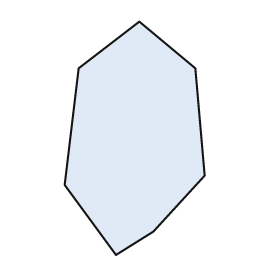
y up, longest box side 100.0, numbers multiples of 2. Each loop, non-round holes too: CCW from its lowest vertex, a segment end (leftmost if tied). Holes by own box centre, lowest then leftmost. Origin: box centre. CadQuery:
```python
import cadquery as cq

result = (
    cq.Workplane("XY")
    .moveTo(-8.0, -50.0)
    .lineTo(8.0, -40.0)
    .lineTo(30.0, -16.0)
    .lineTo(26.0, 30.0)
    .lineTo(2.0, 50.0)
    .lineTo(-24.0, 30.0)
    .lineTo(-30.0, -20.0)
    .close()
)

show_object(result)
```